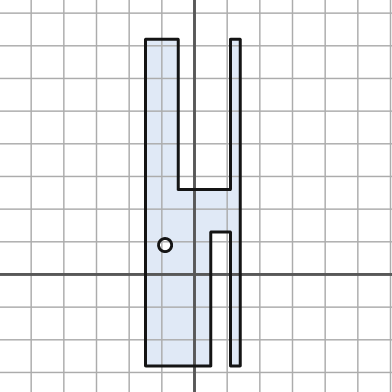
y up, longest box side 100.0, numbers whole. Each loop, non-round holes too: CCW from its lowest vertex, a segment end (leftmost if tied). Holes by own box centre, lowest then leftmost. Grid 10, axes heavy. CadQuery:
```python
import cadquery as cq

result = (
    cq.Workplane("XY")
    .moveTo(-15.0, -28.0)
    .lineTo(5.0, -28.0)
    .lineTo(5.0, 13.0)
    .lineTo(11.0, 13.0)
    .lineTo(11.0, -28.0)
    .lineTo(14.0, -28.0)
    .lineTo(14.0, 72.0)
    .lineTo(11.0, 72.0)
    .lineTo(11.0, 26.0)
    .lineTo(-5.0, 26.0)
    .lineTo(-5.0, 72.0)
    .lineTo(-15.0, 72.0)
    .close()
    .moveTo(-9.0, 9.0)
    .circle(2.0)
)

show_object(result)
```